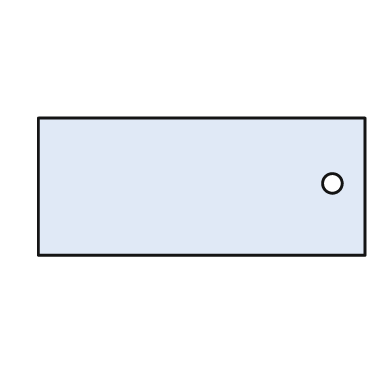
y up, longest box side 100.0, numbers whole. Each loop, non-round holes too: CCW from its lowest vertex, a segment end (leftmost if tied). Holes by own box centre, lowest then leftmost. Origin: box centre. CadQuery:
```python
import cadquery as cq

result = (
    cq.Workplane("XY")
    .moveTo(-50.0, -21.0)
    .lineTo(50.0, -21.0)
    .lineTo(50.0, 21.0)
    .lineTo(-50.0, 21.0)
    .close()
    .moveTo(40.0, 1.0)
    .circle(3.0)
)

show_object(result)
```